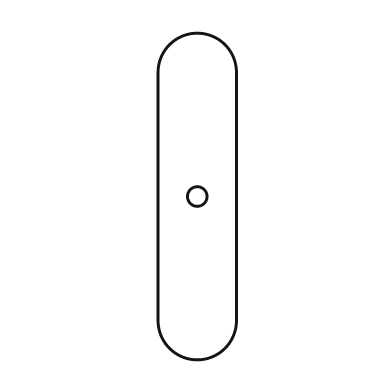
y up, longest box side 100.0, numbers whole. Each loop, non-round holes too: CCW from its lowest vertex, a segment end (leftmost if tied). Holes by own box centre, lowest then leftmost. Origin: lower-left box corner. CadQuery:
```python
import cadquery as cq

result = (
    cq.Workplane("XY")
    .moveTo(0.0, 12.0)
    .threePointArc((12.0, 0.0), (24.0, 12.0))
    .lineTo(24.0, 88.0)
    .threePointArc((12.0, 100.0), (0.0, 88.0))
    .close()
    .moveTo(12.0, 50.0)
    .circle(3.0)
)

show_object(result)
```